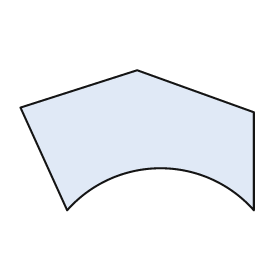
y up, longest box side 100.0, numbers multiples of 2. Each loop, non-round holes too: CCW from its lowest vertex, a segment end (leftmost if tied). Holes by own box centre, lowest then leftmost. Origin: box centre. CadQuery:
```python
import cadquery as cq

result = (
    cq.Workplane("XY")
    .moveTo(-30.0, -30.0)
    .threePointArc((10.0, -12.0), (50.0, -30.0))
    .lineTo(50.0, 12.0)
    .lineTo(0.0, 30.0)
    .lineTo(-50.0, 14.0)
    .close()
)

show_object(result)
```